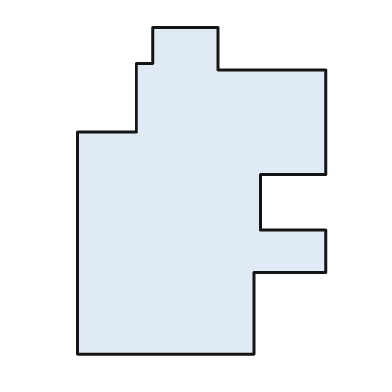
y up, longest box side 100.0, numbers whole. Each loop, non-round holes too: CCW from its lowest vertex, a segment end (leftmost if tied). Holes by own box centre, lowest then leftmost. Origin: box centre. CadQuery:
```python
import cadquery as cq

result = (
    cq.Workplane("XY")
    .moveTo(-38.0, -50.0)
    .lineTo(16.0, -50.0)
    .lineTo(16.0, -25.0)
    .lineTo(38.0, -25.0)
    .lineTo(38.0, -12.0)
    .lineTo(18.0, -12.0)
    .lineTo(18.0, 5.0)
    .lineTo(38.0, 5.0)
    .lineTo(38.0, 37.0)
    .lineTo(5.0, 37.0)
    .lineTo(5.0, 50.0)
    .lineTo(-15.0, 50.0)
    .lineTo(-15.0, 39.0)
    .lineTo(-20.0, 39.0)
    .lineTo(-20.0, 18.0)
    .lineTo(-38.0, 18.0)
    .close()
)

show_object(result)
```